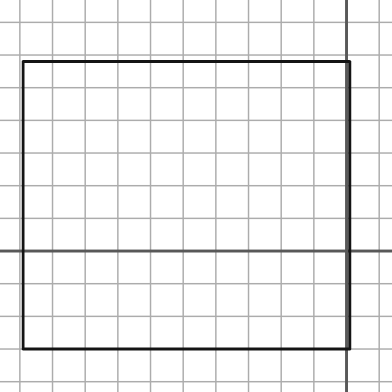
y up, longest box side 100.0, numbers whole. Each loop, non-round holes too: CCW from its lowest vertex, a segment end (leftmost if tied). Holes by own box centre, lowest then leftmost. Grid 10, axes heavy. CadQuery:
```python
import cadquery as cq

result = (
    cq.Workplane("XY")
    .moveTo(-99.0, -30.0)
    .lineTo(1.0, -30.0)
    .lineTo(1.0, 58.0)
    .lineTo(-99.0, 58.0)
    .close()
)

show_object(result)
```